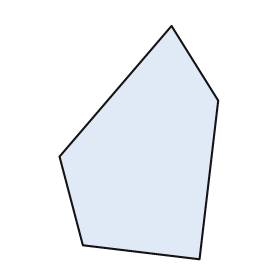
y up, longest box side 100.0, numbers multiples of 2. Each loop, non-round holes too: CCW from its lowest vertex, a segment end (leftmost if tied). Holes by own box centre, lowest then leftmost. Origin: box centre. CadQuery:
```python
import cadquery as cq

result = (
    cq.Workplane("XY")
    .moveTo(26.0, -50.0)
    .lineTo(34.0, 18.0)
    .lineTo(14.0, 50.0)
    .lineTo(-34.0, -6.0)
    .lineTo(-24.0, -44.0)
    .close()
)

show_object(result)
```